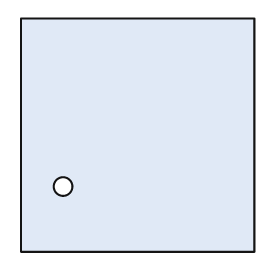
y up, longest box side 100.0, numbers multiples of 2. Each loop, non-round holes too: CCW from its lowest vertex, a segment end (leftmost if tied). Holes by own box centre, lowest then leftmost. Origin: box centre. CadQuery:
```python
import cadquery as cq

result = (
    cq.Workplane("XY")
    .moveTo(-50.0, -50.0)
    .lineTo(50.0, -50.0)
    .lineTo(50.0, 50.0)
    .lineTo(-50.0, 50.0)
    .close()
    .moveTo(-32.0, -22.0)
    .circle(4.0)
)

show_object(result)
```